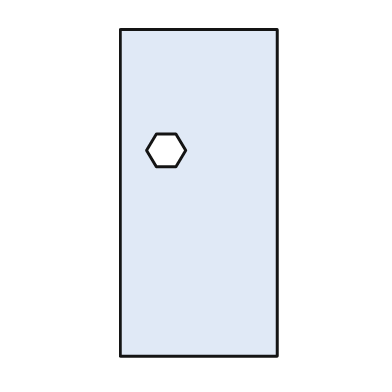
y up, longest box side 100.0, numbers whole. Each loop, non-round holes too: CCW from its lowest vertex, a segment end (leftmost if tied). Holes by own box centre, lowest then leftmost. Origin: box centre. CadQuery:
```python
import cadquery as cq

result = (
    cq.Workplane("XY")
    .moveTo(-24.0, -50.0)
    .lineTo(24.0, -50.0)
    .lineTo(24.0, 50.0)
    .lineTo(-24.0, 50.0)
    .close()
    .moveTo(-13.0, 8.0)
    .lineTo(-7.0, 8.0)
    .lineTo(-4.0, 13.0)
    .lineTo(-7.0, 18.0)
    .lineTo(-13.0, 18.0)
    .lineTo(-16.0, 13.0)
    .close()
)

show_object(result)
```